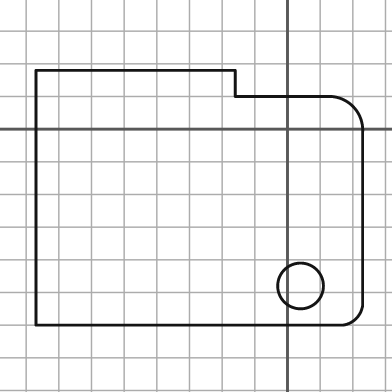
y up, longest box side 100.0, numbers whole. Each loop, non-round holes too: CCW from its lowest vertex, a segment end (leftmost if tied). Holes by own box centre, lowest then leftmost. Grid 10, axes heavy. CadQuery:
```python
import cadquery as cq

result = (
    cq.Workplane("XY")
    .moveTo(-77.0, -60.0)
    .lineTo(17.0, -60.0)
    .threePointArc((21.0, -58.0), (23.0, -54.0))
    .lineTo(23.0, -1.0)
    .threePointArc((20.0, 7.0), (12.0, 10.0))
    .lineTo(-16.0, 10.0)
    .lineTo(-16.0, 18.0)
    .lineTo(-77.0, 18.0)
    .close()
    .moveTo(4.0, -48.0)
    .circle(7.0)
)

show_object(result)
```